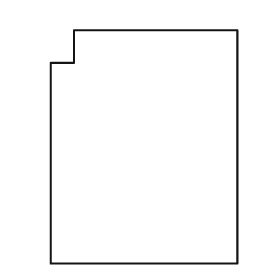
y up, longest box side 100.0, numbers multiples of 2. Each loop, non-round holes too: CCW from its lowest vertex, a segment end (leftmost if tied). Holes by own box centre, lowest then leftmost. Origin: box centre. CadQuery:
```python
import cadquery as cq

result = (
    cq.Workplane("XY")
    .moveTo(-40.0, -50.0)
    .lineTo(40.0, -50.0)
    .lineTo(40.0, 50.0)
    .lineTo(-30.0, 50.0)
    .lineTo(-30.0, 36.0)
    .lineTo(-40.0, 36.0)
    .close()
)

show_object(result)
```